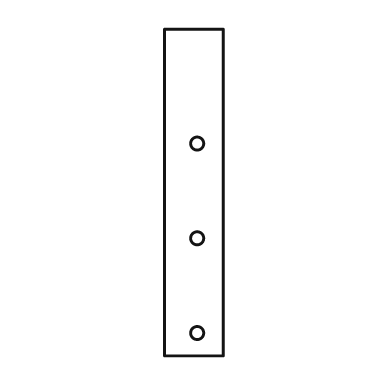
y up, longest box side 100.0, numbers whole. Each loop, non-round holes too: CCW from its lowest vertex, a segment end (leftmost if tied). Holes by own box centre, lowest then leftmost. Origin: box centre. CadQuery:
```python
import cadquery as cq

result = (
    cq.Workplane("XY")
    .moveTo(-9.0, -50.0)
    .lineTo(9.0, -50.0)
    .lineTo(9.0, 50.0)
    .lineTo(-9.0, 50.0)
    .close()
    .moveTo(1.0, -43.0)
    .circle(2.0)
    .moveTo(1.0, -14.0)
    .circle(2.0)
    .moveTo(1.0, 15.0)
    .circle(2.0)
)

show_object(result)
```